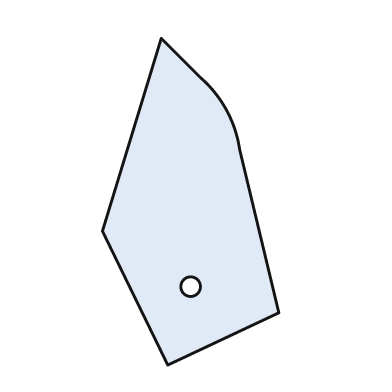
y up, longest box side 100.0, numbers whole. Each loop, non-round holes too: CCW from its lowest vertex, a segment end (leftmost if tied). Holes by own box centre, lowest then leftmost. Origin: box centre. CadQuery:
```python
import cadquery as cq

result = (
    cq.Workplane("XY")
    .moveTo(-7.0, -50.0)
    .lineTo(27.0, -34.0)
    .lineTo(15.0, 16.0)
    .threePointArc((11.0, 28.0), (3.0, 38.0))
    .lineTo(-9.0, 50.0)
    .lineTo(-27.0, -9.0)
    .close()
    .moveTo(0.0, -26.0)
    .circle(3.0)
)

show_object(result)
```